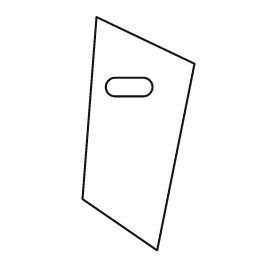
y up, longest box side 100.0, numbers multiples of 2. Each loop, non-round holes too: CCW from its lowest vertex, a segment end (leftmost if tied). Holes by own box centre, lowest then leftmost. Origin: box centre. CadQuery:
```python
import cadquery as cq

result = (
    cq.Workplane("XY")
    .moveTo(8.0, -50.0)
    .lineTo(24.0, 30.0)
    .lineTo(-18.0, 50.0)
    .lineTo(-24.0, -28.0)
    .close()
    .moveTo(-10.0, 16.0)
    .lineTo(2.0, 16.0)
    .threePointArc((6.0, 20.0), (2.0, 24.0))
    .lineTo(-10.0, 24.0)
    .threePointArc((-14.0, 20.0), (-10.0, 16.0))
    .close()
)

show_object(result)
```